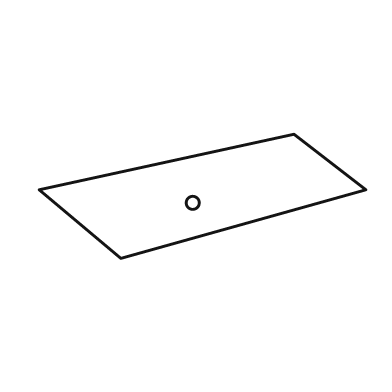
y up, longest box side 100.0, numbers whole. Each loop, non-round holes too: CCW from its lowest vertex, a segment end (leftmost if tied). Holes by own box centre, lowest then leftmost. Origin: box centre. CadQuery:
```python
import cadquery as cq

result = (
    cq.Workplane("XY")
    .moveTo(-25.0, -19.0)
    .lineTo(50.0, 2.0)
    .lineTo(28.0, 19.0)
    .lineTo(-50.0, 2.0)
    .close()
    .moveTo(-3.0, -2.0)
    .circle(2.0)
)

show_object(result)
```